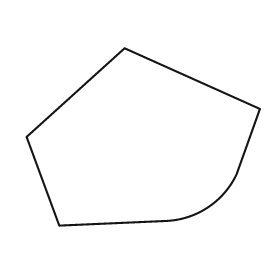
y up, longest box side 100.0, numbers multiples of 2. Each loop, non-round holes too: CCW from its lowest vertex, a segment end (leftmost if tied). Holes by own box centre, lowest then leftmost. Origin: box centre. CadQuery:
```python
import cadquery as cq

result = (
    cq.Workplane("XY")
    .moveTo(-36.0, -38.0)
    .lineTo(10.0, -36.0)
    .threePointArc((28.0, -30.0), (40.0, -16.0))
    .lineTo(50.0, 12.0)
    .lineTo(-8.0, 38.0)
    .lineTo(-50.0, 0.0)
    .close()
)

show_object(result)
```